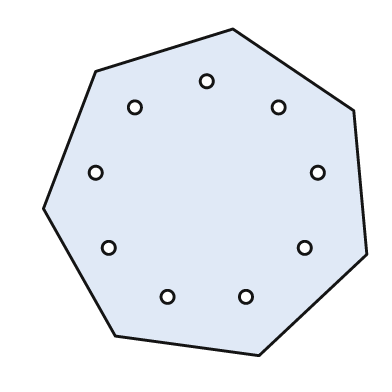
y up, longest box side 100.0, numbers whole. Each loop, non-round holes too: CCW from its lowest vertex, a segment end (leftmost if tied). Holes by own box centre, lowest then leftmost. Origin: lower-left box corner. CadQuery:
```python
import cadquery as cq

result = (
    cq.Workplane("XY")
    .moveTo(66.0, 0.0)
    .lineTo(99.0, 31.0)
    .lineTo(95.0, 75.0)
    .lineTo(58.0, 100.0)
    .lineTo(16.0, 87.0)
    .lineTo(0.0, 45.0)
    .lineTo(22.0, 6.0)
    .close()
    .moveTo(38.0, 18.0)
    .circle(2.0)
    .moveTo(62.0, 18.0)
    .circle(2.0)
    .moveTo(20.0, 33.0)
    .circle(2.0)
    .moveTo(80.0, 33.0)
    .circle(2.0)
    .moveTo(16.0, 56.0)
    .circle(2.0)
    .moveTo(84.0, 56.0)
    .circle(2.0)
    .moveTo(28.0, 76.0)
    .circle(2.0)
    .moveTo(72.0, 76.0)
    .circle(2.0)
    .moveTo(50.0, 84.0)
    .circle(2.0)
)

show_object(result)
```